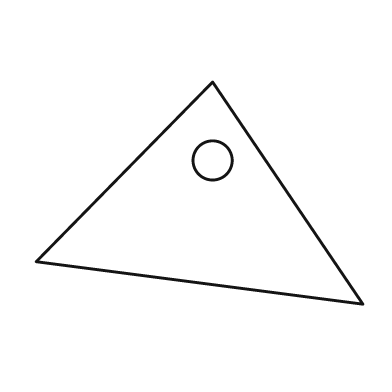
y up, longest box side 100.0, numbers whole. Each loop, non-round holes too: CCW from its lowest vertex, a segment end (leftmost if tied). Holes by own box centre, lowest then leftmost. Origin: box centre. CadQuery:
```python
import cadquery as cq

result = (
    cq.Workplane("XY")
    .moveTo(50.0, -34.0)
    .lineTo(4.0, 34.0)
    .lineTo(-50.0, -21.0)
    .close()
    .moveTo(4.0, 10.0)
    .circle(6.0)
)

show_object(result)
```